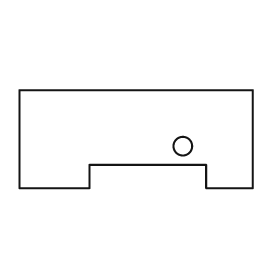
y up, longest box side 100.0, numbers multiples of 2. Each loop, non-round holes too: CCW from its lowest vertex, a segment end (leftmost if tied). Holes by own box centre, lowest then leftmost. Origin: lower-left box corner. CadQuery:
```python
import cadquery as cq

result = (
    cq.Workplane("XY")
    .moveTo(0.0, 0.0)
    .lineTo(30.0, 0.0)
    .lineTo(30.0, 10.0)
    .lineTo(80.0, 10.0)
    .lineTo(80.0, 0.0)
    .lineTo(100.0, 0.0)
    .lineTo(100.0, 42.0)
    .lineTo(0.0, 42.0)
    .close()
    .moveTo(70.0, 18.0)
    .circle(4.0)
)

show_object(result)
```